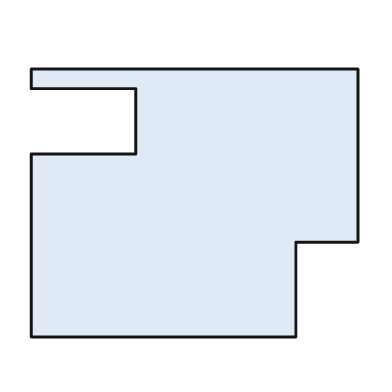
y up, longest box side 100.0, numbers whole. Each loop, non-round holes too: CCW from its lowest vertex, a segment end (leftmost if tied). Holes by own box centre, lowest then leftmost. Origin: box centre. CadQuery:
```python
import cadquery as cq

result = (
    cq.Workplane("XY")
    .moveTo(-50.0, -41.0)
    .lineTo(31.0, -41.0)
    .lineTo(31.0, -12.0)
    .lineTo(50.0, -12.0)
    .lineTo(50.0, 41.0)
    .lineTo(-50.0, 41.0)
    .lineTo(-50.0, 35.0)
    .lineTo(-18.0, 35.0)
    .lineTo(-18.0, 15.0)
    .lineTo(-50.0, 15.0)
    .close()
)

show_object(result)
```